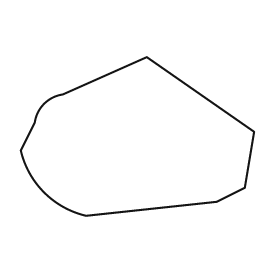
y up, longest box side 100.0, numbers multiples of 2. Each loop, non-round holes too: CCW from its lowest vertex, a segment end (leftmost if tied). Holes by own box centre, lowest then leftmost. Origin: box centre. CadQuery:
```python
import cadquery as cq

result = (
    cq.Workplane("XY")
    .moveTo(-22.0, -34.0)
    .lineTo(34.0, -28.0)
    .lineTo(46.0, -22.0)
    .lineTo(50.0, 2.0)
    .lineTo(4.0, 34.0)
    .lineTo(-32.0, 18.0)
    .threePointArc((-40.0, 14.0), (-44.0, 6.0))
    .lineTo(-50.0, -6.0)
    .threePointArc((-40.0, -24.0), (-22.0, -34.0))
    .close()
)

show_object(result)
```